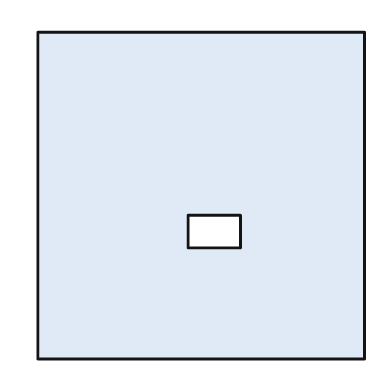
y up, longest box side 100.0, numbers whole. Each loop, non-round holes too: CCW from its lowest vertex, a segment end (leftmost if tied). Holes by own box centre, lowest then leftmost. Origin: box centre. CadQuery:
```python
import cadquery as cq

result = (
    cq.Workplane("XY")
    .moveTo(-50.0, -50.0)
    .lineTo(50.0, -50.0)
    .lineTo(50.0, 50.0)
    .lineTo(-50.0, 50.0)
    .close()
    .moveTo(-4.0, -16.0)
    .lineTo(12.0, -16.0)
    .lineTo(12.0, -6.0)
    .lineTo(-4.0, -6.0)
    .close()
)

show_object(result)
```